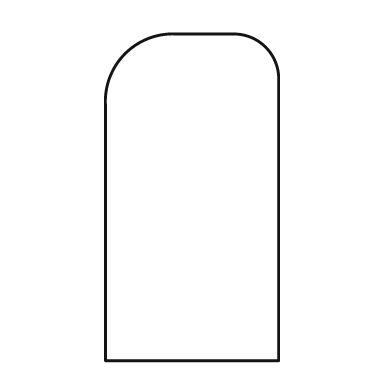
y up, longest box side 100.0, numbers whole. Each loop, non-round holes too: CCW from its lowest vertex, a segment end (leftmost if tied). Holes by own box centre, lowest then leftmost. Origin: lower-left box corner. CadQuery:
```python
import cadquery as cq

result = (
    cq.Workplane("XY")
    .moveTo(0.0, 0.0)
    .lineTo(53.0, 0.0)
    .lineTo(53.0, 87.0)
    .threePointArc((49.0, 96.0), (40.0, 100.0))
    .lineTo(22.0, 100.0)
    .threePointArc((6.0, 94.0), (0.0, 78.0))
    .close()
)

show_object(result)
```